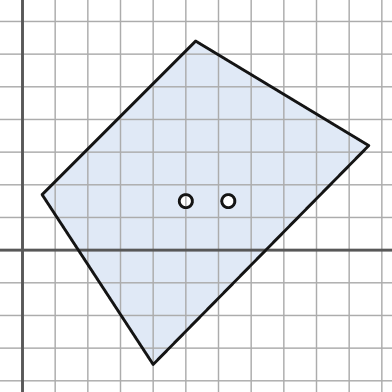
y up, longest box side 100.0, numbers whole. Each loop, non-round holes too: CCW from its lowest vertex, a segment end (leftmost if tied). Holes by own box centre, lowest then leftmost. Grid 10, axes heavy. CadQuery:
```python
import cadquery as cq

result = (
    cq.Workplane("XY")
    .moveTo(40.0, -35.0)
    .lineTo(106.0, 32.0)
    .lineTo(53.0, 64.0)
    .lineTo(6.0, 17.0)
    .close()
    .moveTo(50.0, 15.0)
    .circle(2.0)
    .moveTo(63.0, 15.0)
    .circle(2.0)
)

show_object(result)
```